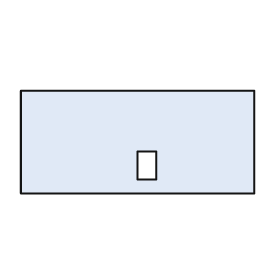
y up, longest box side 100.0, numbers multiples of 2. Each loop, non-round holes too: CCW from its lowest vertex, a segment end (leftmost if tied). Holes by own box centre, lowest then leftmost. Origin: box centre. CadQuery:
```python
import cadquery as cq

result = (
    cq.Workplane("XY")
    .moveTo(-50.0, -22.0)
    .lineTo(50.0, -22.0)
    .lineTo(50.0, 22.0)
    .lineTo(-50.0, 22.0)
    .close()
    .moveTo(0.0, -16.0)
    .lineTo(8.0, -16.0)
    .lineTo(8.0, -4.0)
    .lineTo(0.0, -4.0)
    .close()
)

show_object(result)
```